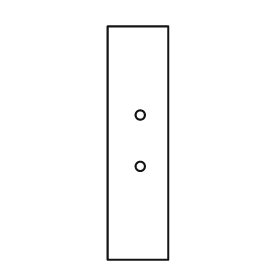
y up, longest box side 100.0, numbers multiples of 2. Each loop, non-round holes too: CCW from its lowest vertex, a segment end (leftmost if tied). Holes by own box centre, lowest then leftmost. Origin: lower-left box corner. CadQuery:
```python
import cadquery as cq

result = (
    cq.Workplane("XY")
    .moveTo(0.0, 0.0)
    .lineTo(26.0, 0.0)
    .lineTo(26.0, 100.0)
    .lineTo(0.0, 100.0)
    .close()
    .moveTo(14.0, 40.0)
    .circle(2.0)
    .moveTo(14.0, 62.0)
    .circle(2.0)
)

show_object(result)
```